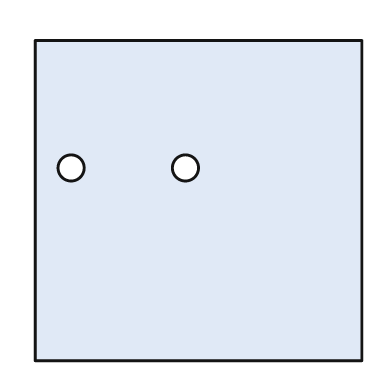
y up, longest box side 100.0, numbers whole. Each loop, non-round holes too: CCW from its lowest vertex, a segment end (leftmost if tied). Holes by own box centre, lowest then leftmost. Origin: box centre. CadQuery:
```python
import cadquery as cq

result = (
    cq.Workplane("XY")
    .moveTo(-50.0, -49.0)
    .lineTo(50.0, -49.0)
    .lineTo(50.0, 49.0)
    .lineTo(-50.0, 49.0)
    .close()
    .moveTo(-39.0, 10.0)
    .circle(4.0)
    .moveTo(-4.0, 10.0)
    .circle(4.0)
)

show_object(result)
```